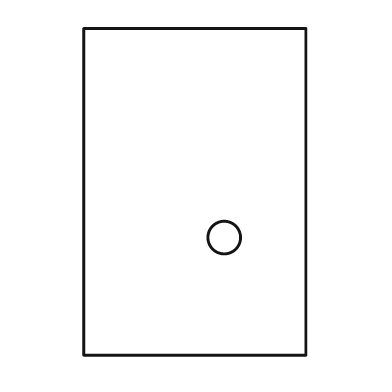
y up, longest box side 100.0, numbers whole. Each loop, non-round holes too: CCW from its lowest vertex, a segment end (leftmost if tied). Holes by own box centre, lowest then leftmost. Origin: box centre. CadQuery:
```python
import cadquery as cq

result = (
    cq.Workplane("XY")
    .moveTo(-34.0, -50.0)
    .lineTo(34.0, -50.0)
    .lineTo(34.0, 50.0)
    .lineTo(-34.0, 50.0)
    .close()
    .moveTo(9.0, -14.0)
    .circle(5.0)
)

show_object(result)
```